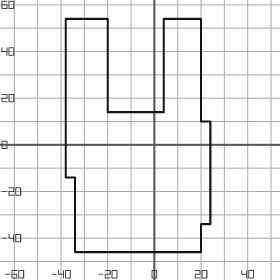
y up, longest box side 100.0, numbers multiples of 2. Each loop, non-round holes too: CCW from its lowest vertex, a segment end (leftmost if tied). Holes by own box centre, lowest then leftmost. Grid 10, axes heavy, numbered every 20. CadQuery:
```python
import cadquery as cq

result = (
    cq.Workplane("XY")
    .moveTo(-34.0, -46.0)
    .lineTo(20.0, -46.0)
    .lineTo(20.0, -34.0)
    .lineTo(24.0, -34.0)
    .lineTo(24.0, 10.0)
    .lineTo(20.0, 10.0)
    .lineTo(20.0, 54.0)
    .lineTo(4.0, 54.0)
    .lineTo(4.0, 14.0)
    .lineTo(-20.0, 14.0)
    .lineTo(-20.0, 54.0)
    .lineTo(-38.0, 54.0)
    .lineTo(-38.0, -14.0)
    .lineTo(-34.0, -14.0)
    .close()
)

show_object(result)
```